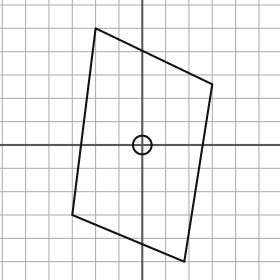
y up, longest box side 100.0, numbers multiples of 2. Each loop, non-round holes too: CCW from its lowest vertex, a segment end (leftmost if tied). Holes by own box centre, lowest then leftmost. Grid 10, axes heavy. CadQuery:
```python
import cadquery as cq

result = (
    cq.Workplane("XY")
    .moveTo(18.0, -50.0)
    .lineTo(30.0, 26.0)
    .lineTo(-20.0, 50.0)
    .lineTo(-30.0, -30.0)
    .close()
    .moveTo(0.0, 0.0)
    .circle(4.0)
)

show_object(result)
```